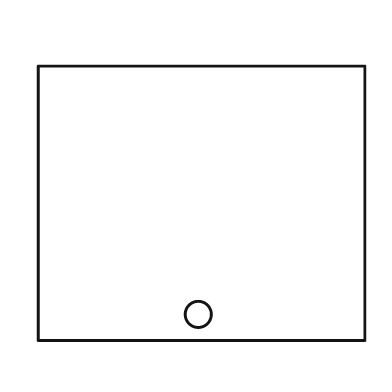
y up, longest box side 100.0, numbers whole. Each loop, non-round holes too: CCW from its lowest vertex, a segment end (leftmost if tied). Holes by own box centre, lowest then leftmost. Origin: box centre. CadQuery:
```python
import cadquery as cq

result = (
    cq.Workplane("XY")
    .moveTo(-50.0, -42.0)
    .lineTo(50.0, -42.0)
    .lineTo(50.0, 42.0)
    .lineTo(-50.0, 42.0)
    .close()
    .moveTo(-1.0, -34.0)
    .circle(4.0)
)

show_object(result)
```